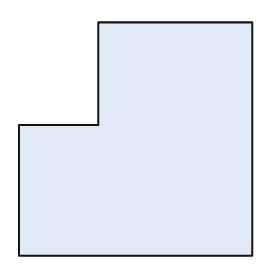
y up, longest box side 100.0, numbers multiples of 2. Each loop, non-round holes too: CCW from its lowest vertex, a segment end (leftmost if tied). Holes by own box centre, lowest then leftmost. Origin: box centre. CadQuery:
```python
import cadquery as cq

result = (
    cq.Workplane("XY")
    .moveTo(-50.0, -50.0)
    .lineTo(50.0, -50.0)
    .lineTo(50.0, 50.0)
    .lineTo(-16.0, 50.0)
    .lineTo(-16.0, 6.0)
    .lineTo(-50.0, 6.0)
    .close()
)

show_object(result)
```